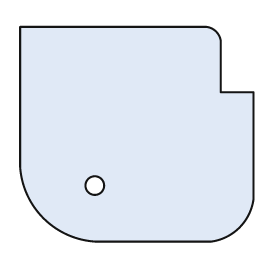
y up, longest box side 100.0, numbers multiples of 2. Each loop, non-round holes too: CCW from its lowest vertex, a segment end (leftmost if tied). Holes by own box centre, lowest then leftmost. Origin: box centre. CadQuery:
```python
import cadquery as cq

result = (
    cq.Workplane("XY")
    .moveTo(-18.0, -46.0)
    .lineTo(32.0, -46.0)
    .threePointArc((44.0, -40.0), (50.0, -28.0))
    .lineTo(50.0, 18.0)
    .lineTo(36.0, 18.0)
    .lineTo(36.0, 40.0)
    .threePointArc((34.0, 44.0), (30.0, 46.0))
    .lineTo(-50.0, 46.0)
    .lineTo(-50.0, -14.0)
    .threePointArc((-40.0, -36.0), (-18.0, -46.0))
    .close()
    .moveTo(-18.0, -22.0)
    .circle(4.0)
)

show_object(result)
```